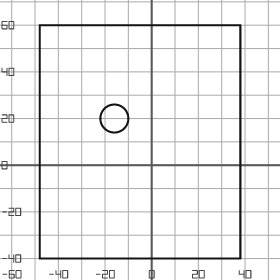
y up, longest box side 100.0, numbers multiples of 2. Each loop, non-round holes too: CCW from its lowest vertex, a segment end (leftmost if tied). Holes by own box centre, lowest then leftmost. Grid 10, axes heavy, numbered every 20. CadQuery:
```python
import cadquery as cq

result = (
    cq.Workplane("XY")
    .moveTo(-48.0, -40.0)
    .lineTo(38.0, -40.0)
    .lineTo(38.0, 60.0)
    .lineTo(-48.0, 60.0)
    .close()
    .moveTo(-16.0, 20.0)
    .circle(6.0)
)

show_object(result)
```